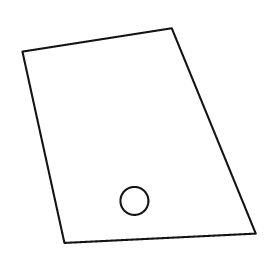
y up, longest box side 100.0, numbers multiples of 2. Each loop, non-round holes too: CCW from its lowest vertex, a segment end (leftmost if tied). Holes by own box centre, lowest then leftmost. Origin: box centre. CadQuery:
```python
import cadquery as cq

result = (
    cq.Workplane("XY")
    .moveTo(-32.0, -46.0)
    .lineTo(50.0, -42.0)
    .lineTo(14.0, 46.0)
    .lineTo(-50.0, 36.0)
    .close()
    .moveTo(-2.0, -28.0)
    .circle(6.0)
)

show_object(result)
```